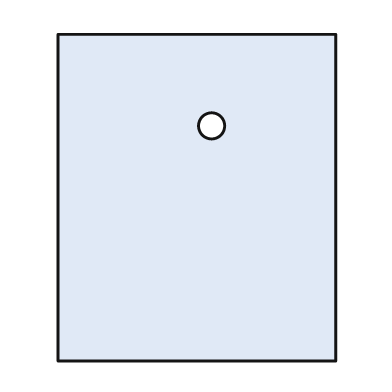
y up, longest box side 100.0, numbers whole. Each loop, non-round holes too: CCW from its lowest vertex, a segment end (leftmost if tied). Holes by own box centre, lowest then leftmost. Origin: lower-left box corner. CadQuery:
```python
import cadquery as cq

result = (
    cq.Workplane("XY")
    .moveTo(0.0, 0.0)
    .lineTo(85.0, 0.0)
    .lineTo(85.0, 100.0)
    .lineTo(0.0, 100.0)
    .close()
    .moveTo(47.0, 72.0)
    .circle(4.0)
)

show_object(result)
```